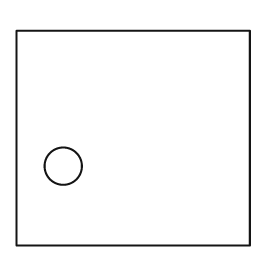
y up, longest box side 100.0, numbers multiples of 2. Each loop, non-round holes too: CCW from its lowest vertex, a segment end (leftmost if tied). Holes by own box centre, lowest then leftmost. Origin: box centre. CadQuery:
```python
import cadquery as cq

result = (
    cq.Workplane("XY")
    .moveTo(-50.0, -46.0)
    .lineTo(50.0, -46.0)
    .lineTo(50.0, 46.0)
    .lineTo(-50.0, 46.0)
    .close()
    .moveTo(-30.0, -12.0)
    .circle(8.0)
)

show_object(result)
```